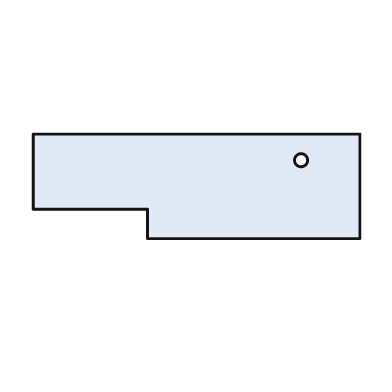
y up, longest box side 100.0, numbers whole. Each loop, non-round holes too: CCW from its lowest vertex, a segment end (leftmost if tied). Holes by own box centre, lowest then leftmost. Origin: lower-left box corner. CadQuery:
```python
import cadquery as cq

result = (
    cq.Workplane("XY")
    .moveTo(35.0, 0.0)
    .lineTo(100.0, 0.0)
    .lineTo(100.0, 32.0)
    .lineTo(0.0, 32.0)
    .lineTo(0.0, 9.0)
    .lineTo(35.0, 9.0)
    .close()
    .moveTo(82.0, 24.0)
    .circle(2.0)
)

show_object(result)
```